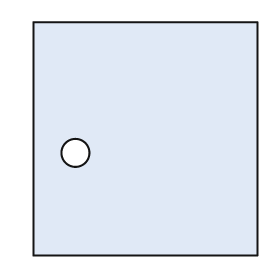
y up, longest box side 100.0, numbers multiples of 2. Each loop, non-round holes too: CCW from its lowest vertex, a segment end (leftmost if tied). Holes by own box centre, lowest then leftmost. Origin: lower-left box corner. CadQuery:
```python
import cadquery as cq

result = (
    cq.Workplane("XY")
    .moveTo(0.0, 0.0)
    .lineTo(96.0, 0.0)
    .lineTo(96.0, 100.0)
    .lineTo(0.0, 100.0)
    .close()
    .moveTo(18.0, 44.0)
    .circle(6.0)
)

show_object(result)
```